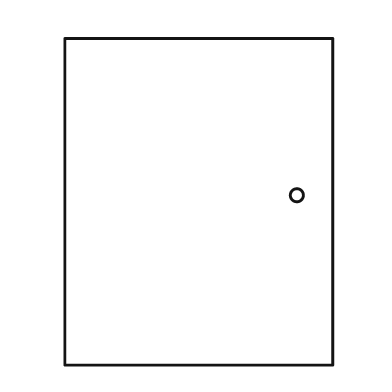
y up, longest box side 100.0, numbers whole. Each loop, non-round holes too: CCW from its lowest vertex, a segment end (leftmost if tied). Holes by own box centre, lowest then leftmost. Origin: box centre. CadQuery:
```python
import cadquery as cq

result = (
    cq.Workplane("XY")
    .moveTo(-41.0, -50.0)
    .lineTo(41.0, -50.0)
    .lineTo(41.0, 50.0)
    .lineTo(-41.0, 50.0)
    .close()
    .moveTo(30.0, 2.0)
    .circle(2.0)
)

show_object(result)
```